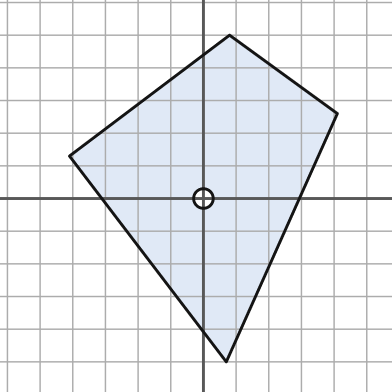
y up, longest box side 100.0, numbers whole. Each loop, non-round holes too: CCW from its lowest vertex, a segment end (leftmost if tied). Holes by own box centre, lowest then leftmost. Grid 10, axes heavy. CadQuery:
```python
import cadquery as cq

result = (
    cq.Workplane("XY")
    .moveTo(7.0, -50.0)
    .lineTo(41.0, 26.0)
    .lineTo(8.0, 50.0)
    .lineTo(-41.0, 13.0)
    .close()
    .moveTo(0.0, 0.0)
    .circle(3.0)
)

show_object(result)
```